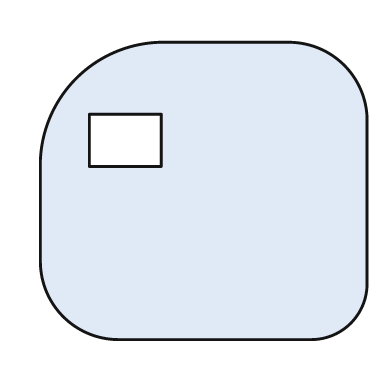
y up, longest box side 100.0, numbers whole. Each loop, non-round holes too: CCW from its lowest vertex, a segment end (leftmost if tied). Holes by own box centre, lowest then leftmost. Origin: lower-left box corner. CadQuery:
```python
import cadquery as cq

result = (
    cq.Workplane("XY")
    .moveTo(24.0, 0.0)
    .lineTo(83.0, 0.0)
    .threePointArc((95.0, 5.0), (100.0, 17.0))
    .lineTo(100.0, 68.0)
    .threePointArc((93.0, 84.0), (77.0, 91.0))
    .lineTo(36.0, 91.0)
    .threePointArc((11.0, 80.0), (0.0, 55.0))
    .lineTo(0.0, 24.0)
    .threePointArc((7.0, 7.0), (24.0, 0.0))
    .close()
    .moveTo(15.0, 53.0)
    .lineTo(37.0, 53.0)
    .lineTo(37.0, 69.0)
    .lineTo(15.0, 69.0)
    .close()
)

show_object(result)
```